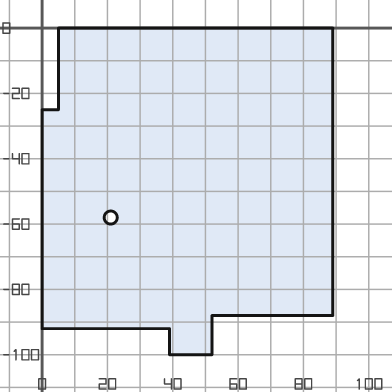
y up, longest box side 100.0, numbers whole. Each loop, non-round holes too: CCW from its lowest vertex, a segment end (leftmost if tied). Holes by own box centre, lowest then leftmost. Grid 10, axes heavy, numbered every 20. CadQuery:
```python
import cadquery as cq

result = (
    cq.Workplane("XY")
    .moveTo(39.0, -100.0)
    .lineTo(52.0, -100.0)
    .lineTo(52.0, -88.0)
    .lineTo(89.0, -88.0)
    .lineTo(89.0, 0.0)
    .lineTo(5.0, 0.0)
    .lineTo(5.0, -25.0)
    .lineTo(0.0, -25.0)
    .lineTo(0.0, -92.0)
    .lineTo(39.0, -92.0)
    .close()
    .moveTo(21.0, -58.0)
    .circle(2.0)
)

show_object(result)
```